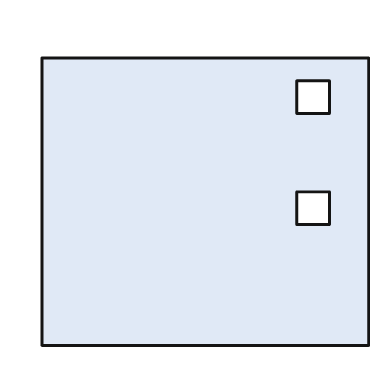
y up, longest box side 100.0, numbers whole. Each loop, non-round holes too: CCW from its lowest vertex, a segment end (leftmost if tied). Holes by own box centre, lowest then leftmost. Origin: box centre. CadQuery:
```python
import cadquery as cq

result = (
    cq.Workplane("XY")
    .moveTo(-50.0, -44.0)
    .lineTo(50.0, -44.0)
    .lineTo(50.0, 44.0)
    .lineTo(-50.0, 44.0)
    .close()
    .moveTo(28.0, -7.0)
    .lineTo(38.0, -7.0)
    .lineTo(38.0, 3.0)
    .lineTo(28.0, 3.0)
    .close()
    .moveTo(28.0, 27.0)
    .lineTo(38.0, 27.0)
    .lineTo(38.0, 37.0)
    .lineTo(28.0, 37.0)
    .close()
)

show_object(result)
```